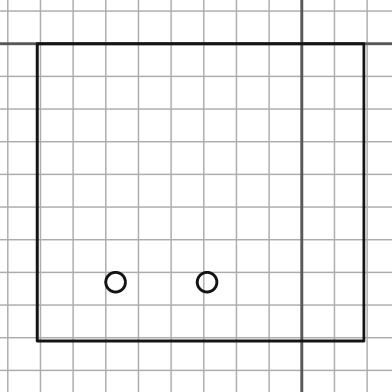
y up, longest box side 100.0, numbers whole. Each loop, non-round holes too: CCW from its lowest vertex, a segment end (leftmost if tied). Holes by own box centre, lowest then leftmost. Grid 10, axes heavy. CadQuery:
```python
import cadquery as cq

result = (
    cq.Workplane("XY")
    .moveTo(-81.0, -91.0)
    .lineTo(19.0, -91.0)
    .lineTo(19.0, 0.0)
    .lineTo(-81.0, 0.0)
    .close()
    .moveTo(-57.0, -73.0)
    .circle(3.0)
    .moveTo(-29.0, -73.0)
    .circle(3.0)
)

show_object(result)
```